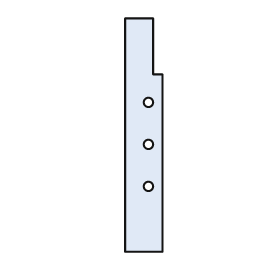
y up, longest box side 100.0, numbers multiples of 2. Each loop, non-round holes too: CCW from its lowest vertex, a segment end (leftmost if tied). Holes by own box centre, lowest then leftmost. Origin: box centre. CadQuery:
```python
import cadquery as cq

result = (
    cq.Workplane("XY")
    .moveTo(-8.0, -50.0)
    .lineTo(8.0, -50.0)
    .lineTo(8.0, 26.0)
    .lineTo(4.0, 26.0)
    .lineTo(4.0, 50.0)
    .lineTo(-8.0, 50.0)
    .close()
    .moveTo(2.0, -22.0)
    .circle(2.0)
    .moveTo(2.0, -4.0)
    .circle(2.0)
    .moveTo(2.0, 14.0)
    .circle(2.0)
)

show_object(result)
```